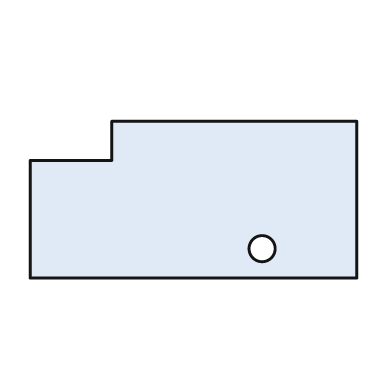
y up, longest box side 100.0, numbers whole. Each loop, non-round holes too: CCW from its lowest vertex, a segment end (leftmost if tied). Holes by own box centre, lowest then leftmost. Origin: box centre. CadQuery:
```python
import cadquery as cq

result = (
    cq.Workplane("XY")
    .moveTo(-50.0, -24.0)
    .lineTo(50.0, -24.0)
    .lineTo(50.0, 24.0)
    .lineTo(-25.0, 24.0)
    .lineTo(-25.0, 12.0)
    .lineTo(-50.0, 12.0)
    .close()
    .moveTo(21.0, -15.0)
    .circle(4.0)
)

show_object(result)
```